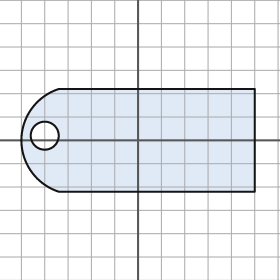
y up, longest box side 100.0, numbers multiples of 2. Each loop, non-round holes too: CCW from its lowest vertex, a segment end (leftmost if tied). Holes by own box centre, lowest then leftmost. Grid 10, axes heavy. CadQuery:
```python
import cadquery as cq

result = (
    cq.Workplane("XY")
    .moveTo(-34.0, -22.0)
    .lineTo(50.0, -22.0)
    .lineTo(50.0, 22.0)
    .lineTo(-34.0, 22.0)
    .threePointArc((-50.0, 0.0), (-34.0, -22.0))
    .close()
    .moveTo(-40.0, 2.0)
    .circle(6.0)
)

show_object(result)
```